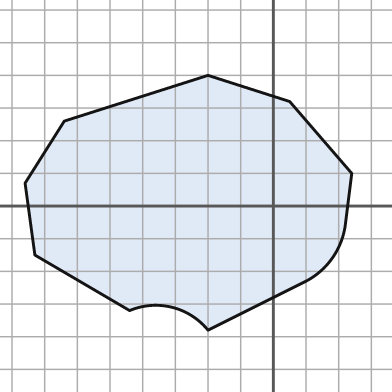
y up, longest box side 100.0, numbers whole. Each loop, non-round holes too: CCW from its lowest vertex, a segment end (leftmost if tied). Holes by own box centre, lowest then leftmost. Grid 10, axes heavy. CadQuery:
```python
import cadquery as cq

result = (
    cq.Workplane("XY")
    .moveTo(-20.0, -38.0)
    .lineTo(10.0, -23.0)
    .threePointArc((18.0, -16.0), (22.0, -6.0))
    .lineTo(24.0, 10.0)
    .lineTo(5.0, 32.0)
    .lineTo(-20.0, 40.0)
    .lineTo(-64.0, 26.0)
    .lineTo(-76.0, 7.0)
    .lineTo(-73.0, -15.0)
    .lineTo(-44.0, -32.0)
    .threePointArc((-31.0, -31.0), (-20.0, -38.0))
    .close()
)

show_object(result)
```